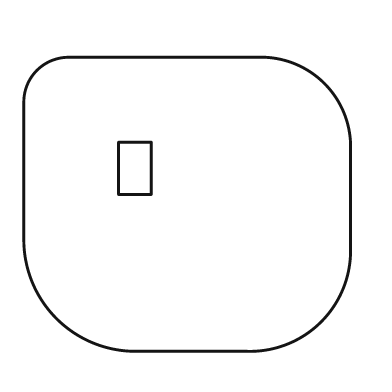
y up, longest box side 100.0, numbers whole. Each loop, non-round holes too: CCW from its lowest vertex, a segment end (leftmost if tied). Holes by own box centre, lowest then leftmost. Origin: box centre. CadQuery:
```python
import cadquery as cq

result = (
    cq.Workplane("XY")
    .moveTo(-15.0, -45.0)
    .lineTo(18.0, -45.0)
    .threePointArc((41.0, -36.0), (50.0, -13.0))
    .lineTo(50.0, 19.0)
    .threePointArc((42.0, 37.0), (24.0, 45.0))
    .lineTo(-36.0, 45.0)
    .threePointArc((-46.0, 41.0), (-50.0, 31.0))
    .lineTo(-50.0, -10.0)
    .threePointArc((-40.0, -35.0), (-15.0, -45.0))
    .close()
    .moveTo(-21.0, 3.0)
    .lineTo(-11.0, 3.0)
    .lineTo(-11.0, 19.0)
    .lineTo(-21.0, 19.0)
    .close()
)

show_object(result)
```